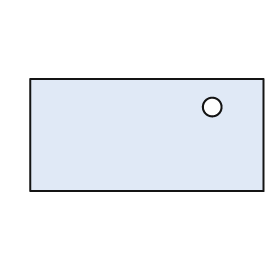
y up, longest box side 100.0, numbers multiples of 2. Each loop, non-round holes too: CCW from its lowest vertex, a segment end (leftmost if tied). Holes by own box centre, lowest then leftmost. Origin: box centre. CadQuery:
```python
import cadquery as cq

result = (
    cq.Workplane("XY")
    .moveTo(-50.0, -24.0)
    .lineTo(50.0, -24.0)
    .lineTo(50.0, 24.0)
    .lineTo(-50.0, 24.0)
    .close()
    .moveTo(28.0, 12.0)
    .circle(4.0)
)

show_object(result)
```